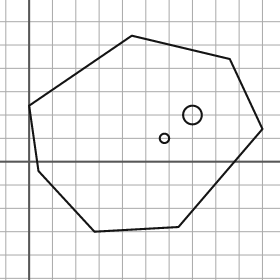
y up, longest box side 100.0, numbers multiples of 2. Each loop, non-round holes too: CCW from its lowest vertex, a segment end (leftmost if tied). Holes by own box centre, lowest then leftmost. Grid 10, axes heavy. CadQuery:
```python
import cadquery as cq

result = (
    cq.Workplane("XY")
    .moveTo(28.0, -30.0)
    .lineTo(64.0, -28.0)
    .lineTo(100.0, 14.0)
    .lineTo(86.0, 44.0)
    .lineTo(44.0, 54.0)
    .lineTo(0.0, 24.0)
    .lineTo(4.0, -4.0)
    .close()
    .moveTo(58.0, 10.0)
    .circle(2.0)
    .moveTo(70.0, 20.0)
    .circle(4.0)
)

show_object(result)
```